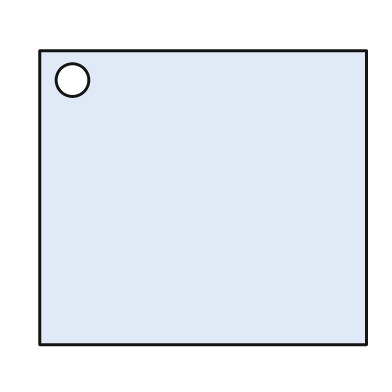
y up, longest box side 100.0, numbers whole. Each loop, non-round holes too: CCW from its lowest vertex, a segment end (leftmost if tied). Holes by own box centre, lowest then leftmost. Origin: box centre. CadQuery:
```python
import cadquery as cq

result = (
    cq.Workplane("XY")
    .moveTo(-50.0, -45.0)
    .lineTo(50.0, -45.0)
    .lineTo(50.0, 45.0)
    .lineTo(-50.0, 45.0)
    .close()
    .moveTo(-40.0, 36.0)
    .circle(5.0)
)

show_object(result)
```